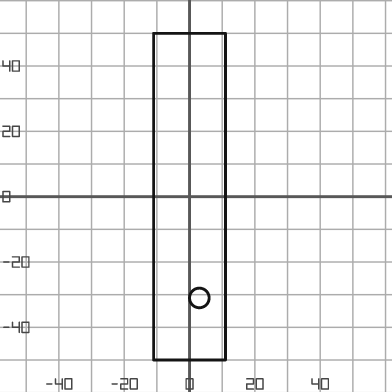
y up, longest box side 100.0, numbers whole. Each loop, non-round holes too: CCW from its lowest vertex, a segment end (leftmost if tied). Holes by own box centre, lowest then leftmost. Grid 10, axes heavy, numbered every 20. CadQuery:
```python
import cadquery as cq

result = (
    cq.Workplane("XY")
    .moveTo(-11.0, -50.0)
    .lineTo(11.0, -50.0)
    .lineTo(11.0, 50.0)
    .lineTo(-11.0, 50.0)
    .close()
    .moveTo(3.0, -31.0)
    .circle(3.0)
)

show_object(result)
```